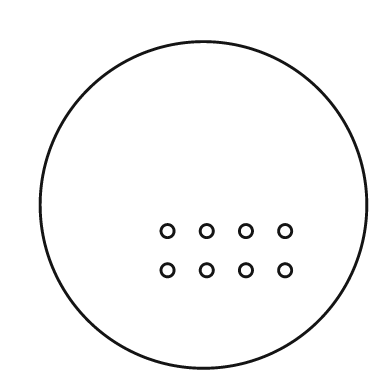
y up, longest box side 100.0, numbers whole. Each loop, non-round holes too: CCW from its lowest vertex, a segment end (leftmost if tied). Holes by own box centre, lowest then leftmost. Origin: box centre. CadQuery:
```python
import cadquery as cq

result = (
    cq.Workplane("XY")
    .moveTo(0.0, 0.0)
    .circle(50.0)
    .moveTo(-11.0, -20.0)
    .circle(2.0)
    .moveTo(1.0, -20.0)
    .circle(2.0)
    .moveTo(13.0, -20.0)
    .circle(2.0)
    .moveTo(25.0, -20.0)
    .circle(2.0)
    .moveTo(-11.0, -8.0)
    .circle(2.0)
    .moveTo(1.0, -8.0)
    .circle(2.0)
    .moveTo(13.0, -8.0)
    .circle(2.0)
    .moveTo(25.0, -8.0)
    .circle(2.0)
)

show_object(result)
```